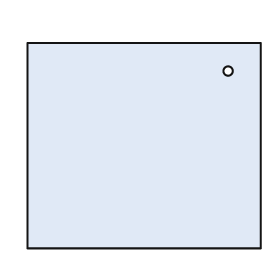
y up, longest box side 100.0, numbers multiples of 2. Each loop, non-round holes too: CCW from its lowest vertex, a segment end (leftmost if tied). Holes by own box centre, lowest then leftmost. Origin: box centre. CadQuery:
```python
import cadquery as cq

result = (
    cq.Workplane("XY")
    .moveTo(-50.0, -44.0)
    .lineTo(50.0, -44.0)
    .lineTo(50.0, 44.0)
    .lineTo(-50.0, 44.0)
    .close()
    .moveTo(36.0, 32.0)
    .circle(2.0)
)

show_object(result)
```